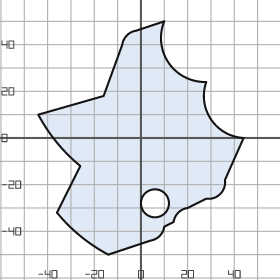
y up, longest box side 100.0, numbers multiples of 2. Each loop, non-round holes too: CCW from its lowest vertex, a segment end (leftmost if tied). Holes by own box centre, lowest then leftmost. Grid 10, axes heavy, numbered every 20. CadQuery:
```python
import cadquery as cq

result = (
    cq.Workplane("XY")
    .moveTo(-14.0, -50.0)
    .lineTo(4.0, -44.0)
    .threePointArc((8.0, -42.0), (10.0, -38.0))
    .lineTo(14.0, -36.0)
    .threePointArc((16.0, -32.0), (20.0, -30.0))
    .lineTo(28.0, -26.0)
    .threePointArc((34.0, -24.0), (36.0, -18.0))
    .lineTo(44.0, 0.0)
    .threePointArc((30.0, 8.0), (28.0, 24.0))
    .threePointArc((12.0, 32.0), (10.0, 50.0))
    .lineTo(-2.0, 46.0)
    .threePointArc((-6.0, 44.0), (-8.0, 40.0))
    .lineTo(-16.0, 18.0)
    .lineTo(-44.0, 10.0)
    .threePointArc((-36.0, -2.0), (-26.0, -12.0))
    .lineTo(-36.0, -32.0)
    .threePointArc((-26.0, -42.0), (-14.0, -50.0))
    .close()
    .moveTo(6.0, -28.0)
    .circle(6.0)
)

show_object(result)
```